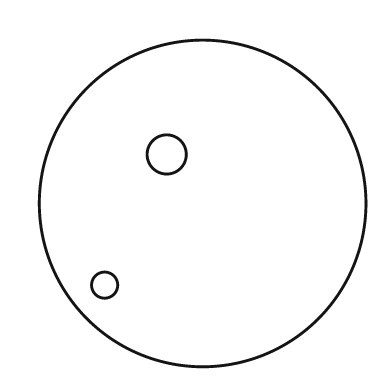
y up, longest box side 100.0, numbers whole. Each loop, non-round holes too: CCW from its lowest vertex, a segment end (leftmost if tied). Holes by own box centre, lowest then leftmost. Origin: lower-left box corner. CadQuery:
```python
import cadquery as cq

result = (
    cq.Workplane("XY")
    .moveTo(50.0, 50.0)
    .circle(50.0)
    .moveTo(20.0, 25.0)
    .circle(4.0)
    .moveTo(39.0, 65.0)
    .circle(6.0)
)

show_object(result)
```